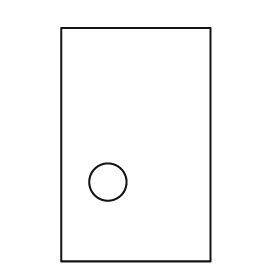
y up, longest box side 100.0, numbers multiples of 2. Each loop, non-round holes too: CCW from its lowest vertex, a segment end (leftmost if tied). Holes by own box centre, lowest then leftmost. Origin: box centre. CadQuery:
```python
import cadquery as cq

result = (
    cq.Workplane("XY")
    .moveTo(-32.0, -50.0)
    .lineTo(32.0, -50.0)
    .lineTo(32.0, 50.0)
    .lineTo(-32.0, 50.0)
    .close()
    .moveTo(-12.0, -16.0)
    .circle(8.0)
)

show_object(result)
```